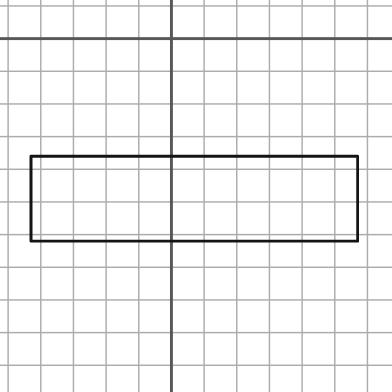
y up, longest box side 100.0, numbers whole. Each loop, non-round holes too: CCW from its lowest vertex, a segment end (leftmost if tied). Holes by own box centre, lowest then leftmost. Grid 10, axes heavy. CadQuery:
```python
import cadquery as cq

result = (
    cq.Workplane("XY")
    .moveTo(-43.0, -62.0)
    .lineTo(57.0, -62.0)
    .lineTo(57.0, -36.0)
    .lineTo(-43.0, -36.0)
    .close()
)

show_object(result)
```